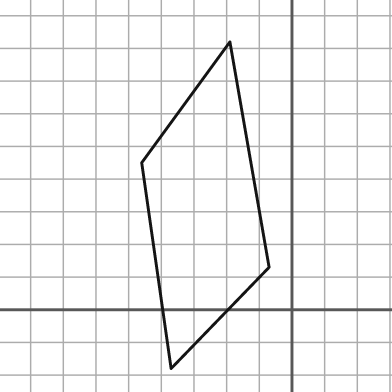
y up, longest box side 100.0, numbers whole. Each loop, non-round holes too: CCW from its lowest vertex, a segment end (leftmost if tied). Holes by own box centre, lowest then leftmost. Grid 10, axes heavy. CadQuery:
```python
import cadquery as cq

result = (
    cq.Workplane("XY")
    .moveTo(-37.0, -18.0)
    .lineTo(-7.0, 13.0)
    .lineTo(-19.0, 82.0)
    .lineTo(-46.0, 45.0)
    .close()
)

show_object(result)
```